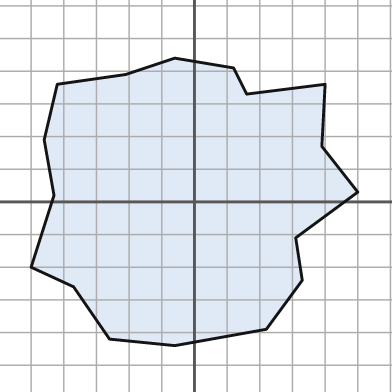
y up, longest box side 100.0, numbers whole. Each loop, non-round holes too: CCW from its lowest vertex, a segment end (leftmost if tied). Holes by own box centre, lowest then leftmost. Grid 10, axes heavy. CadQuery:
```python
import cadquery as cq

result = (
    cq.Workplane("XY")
    .moveTo(-6.0, -44.0)
    .lineTo(22.0, -39.0)
    .lineTo(33.0, -24.0)
    .lineTo(31.0, -11.0)
    .lineTo(50.0, 3.0)
    .lineTo(39.0, 17.0)
    .lineTo(40.0, 36.0)
    .lineTo(16.0, 33.0)
    .lineTo(12.0, 41.0)
    .lineTo(-6.0, 44.0)
    .lineTo(-21.0, 39.0)
    .lineTo(-42.0, 36.0)
    .lineTo(-46.0, 19.0)
    .lineTo(-43.0, 2.0)
    .lineTo(-50.0, -20.0)
    .lineTo(-37.0, -26.0)
    .lineTo(-26.0, -42.0)
    .close()
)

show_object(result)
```